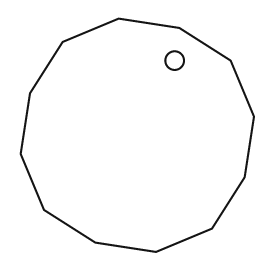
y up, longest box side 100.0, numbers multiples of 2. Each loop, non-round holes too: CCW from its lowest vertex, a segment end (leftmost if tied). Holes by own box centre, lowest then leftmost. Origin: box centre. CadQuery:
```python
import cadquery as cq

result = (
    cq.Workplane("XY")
    .moveTo(8.0, -50.0)
    .lineTo(32.0, -40.0)
    .lineTo(46.0, -18.0)
    .lineTo(50.0, 8.0)
    .lineTo(40.0, 32.0)
    .lineTo(18.0, 46.0)
    .lineTo(-8.0, 50.0)
    .lineTo(-32.0, 40.0)
    .lineTo(-46.0, 18.0)
    .lineTo(-50.0, -8.0)
    .lineTo(-40.0, -32.0)
    .lineTo(-18.0, -46.0)
    .close()
    .moveTo(16.0, 32.0)
    .circle(4.0)
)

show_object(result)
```